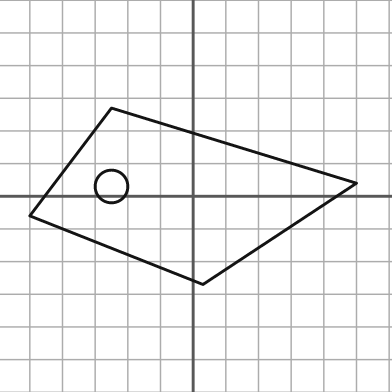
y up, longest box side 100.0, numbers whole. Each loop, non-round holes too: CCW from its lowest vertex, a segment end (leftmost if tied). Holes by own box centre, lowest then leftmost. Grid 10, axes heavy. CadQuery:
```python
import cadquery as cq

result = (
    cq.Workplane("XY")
    .moveTo(3.0, -27.0)
    .lineTo(50.0, 4.0)
    .lineTo(-25.0, 27.0)
    .lineTo(-50.0, -6.0)
    .close()
    .moveTo(-25.0, 3.0)
    .circle(5.0)
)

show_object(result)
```